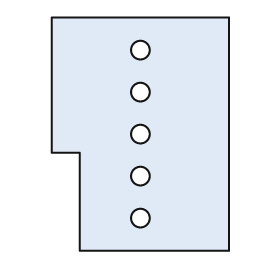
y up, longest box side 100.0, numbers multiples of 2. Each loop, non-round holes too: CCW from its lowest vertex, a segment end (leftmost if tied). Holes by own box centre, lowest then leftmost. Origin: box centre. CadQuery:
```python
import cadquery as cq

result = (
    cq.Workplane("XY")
    .moveTo(-26.0, -50.0)
    .lineTo(38.0, -50.0)
    .lineTo(38.0, 50.0)
    .lineTo(-38.0, 50.0)
    .lineTo(-38.0, -8.0)
    .lineTo(-26.0, -8.0)
    .close()
    .moveTo(0.0, -36.0)
    .circle(4.0)
    .moveTo(0.0, -18.0)
    .circle(4.0)
    .moveTo(0.0, 0.0)
    .circle(4.0)
    .moveTo(0.0, 18.0)
    .circle(4.0)
    .moveTo(0.0, 36.0)
    .circle(4.0)
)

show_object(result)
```